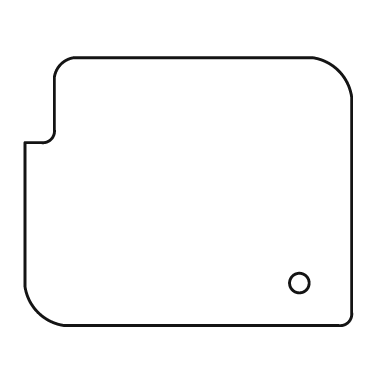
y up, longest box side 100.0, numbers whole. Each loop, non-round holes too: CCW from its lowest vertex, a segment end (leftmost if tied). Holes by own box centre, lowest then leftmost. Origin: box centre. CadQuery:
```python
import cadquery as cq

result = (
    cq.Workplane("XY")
    .moveTo(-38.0, -41.0)
    .lineTo(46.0, -41.0)
    .threePointArc((49.0, -40.0), (50.0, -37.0))
    .lineTo(50.0, 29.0)
    .threePointArc((46.0, 37.0), (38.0, 41.0))
    .lineTo(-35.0, 41.0)
    .threePointArc((-39.0, 39.0), (-41.0, 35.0))
    .lineTo(-41.0, 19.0)
    .threePointArc((-42.0, 16.0), (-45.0, 15.0))
    .lineTo(-50.0, 15.0)
    .lineTo(-50.0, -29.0)
    .threePointArc((-46.0, -37.0), (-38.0, -41.0))
    .close()
    .moveTo(34.0, -28.0)
    .circle(3.0)
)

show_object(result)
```